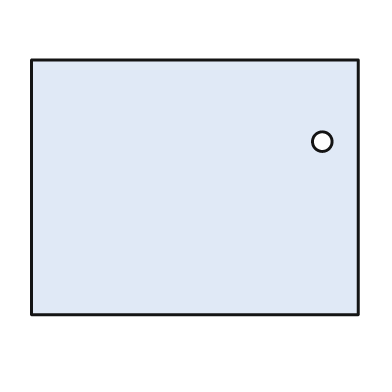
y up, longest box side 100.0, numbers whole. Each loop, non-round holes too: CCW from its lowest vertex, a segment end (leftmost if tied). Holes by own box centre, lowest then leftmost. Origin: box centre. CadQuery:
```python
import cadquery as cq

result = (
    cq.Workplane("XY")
    .moveTo(-50.0, -39.0)
    .lineTo(50.0, -39.0)
    .lineTo(50.0, 39.0)
    .lineTo(-50.0, 39.0)
    .close()
    .moveTo(39.0, 14.0)
    .circle(3.0)
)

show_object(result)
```